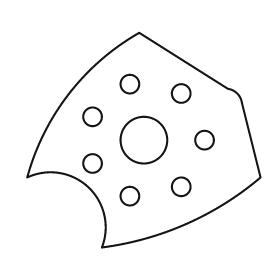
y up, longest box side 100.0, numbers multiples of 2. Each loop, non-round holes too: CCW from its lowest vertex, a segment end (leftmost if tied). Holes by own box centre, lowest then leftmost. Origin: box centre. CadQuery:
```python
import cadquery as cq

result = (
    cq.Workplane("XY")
    .moveTo(-18.0, -46.0)
    .threePointArc((18.0, -36.0), (50.0, -16.0))
    .lineTo(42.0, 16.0)
    .threePointArc((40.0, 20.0), (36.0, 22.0))
    .lineTo(-2.0, 46.0)
    .threePointArc((-32.0, 20.0), (-50.0, -16.0))
    .threePointArc((-24.0, -20.0), (-18.0, -46.0))
    .close()
    .moveTo(-6.0, -24.0)
    .circle(4.0)
    .moveTo(16.0, -20.0)
    .circle(4.0)
    .moveTo(-22.0, -10.0)
    .circle(4.0)
    .moveTo(0.0, 0.0)
    .circle(10.0)
    .moveTo(26.0, 0.0)
    .circle(4.0)
    .moveTo(-22.0, 10.0)
    .circle(4.0)
    .moveTo(16.0, 20.0)
    .circle(4.0)
    .moveTo(-6.0, 24.0)
    .circle(4.0)
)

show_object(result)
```